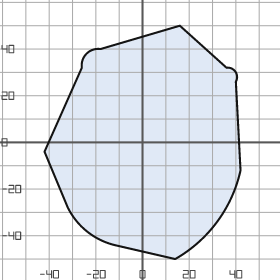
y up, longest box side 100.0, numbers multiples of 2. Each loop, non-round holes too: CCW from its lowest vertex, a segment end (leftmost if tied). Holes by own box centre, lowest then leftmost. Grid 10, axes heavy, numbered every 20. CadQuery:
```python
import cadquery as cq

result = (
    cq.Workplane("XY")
    .moveTo(14.0, -50.0)
    .threePointArc((32.0, -34.0), (42.0, -12.0))
    .lineTo(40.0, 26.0)
    .threePointArc((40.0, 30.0), (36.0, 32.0))
    .lineTo(16.0, 50.0)
    .lineTo(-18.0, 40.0)
    .threePointArc((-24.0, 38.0), (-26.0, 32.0))
    .lineTo(-42.0, -4.0)
    .lineTo(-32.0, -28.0)
    .threePointArc((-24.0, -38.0), (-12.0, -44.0))
    .close()
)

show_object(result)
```